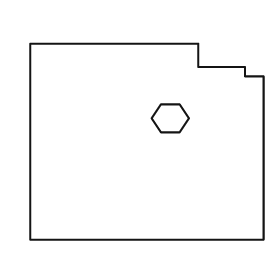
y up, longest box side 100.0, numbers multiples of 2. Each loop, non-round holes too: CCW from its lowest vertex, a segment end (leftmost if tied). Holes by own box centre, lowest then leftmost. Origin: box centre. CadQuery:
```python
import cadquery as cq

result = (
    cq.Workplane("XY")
    .moveTo(-50.0, -42.0)
    .lineTo(50.0, -42.0)
    .lineTo(50.0, 28.0)
    .lineTo(42.0, 28.0)
    .lineTo(42.0, 32.0)
    .lineTo(22.0, 32.0)
    .lineTo(22.0, 42.0)
    .lineTo(-50.0, 42.0)
    .close()
    .moveTo(6.0, 4.0)
    .lineTo(14.0, 4.0)
    .lineTo(18.0, 10.0)
    .lineTo(14.0, 16.0)
    .lineTo(6.0, 16.0)
    .lineTo(2.0, 10.0)
    .close()
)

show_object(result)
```